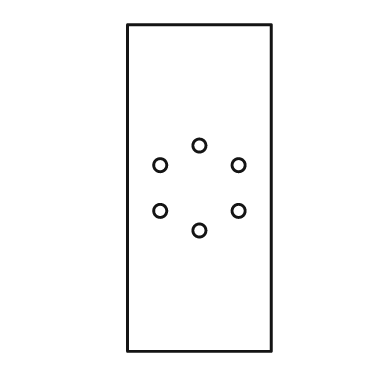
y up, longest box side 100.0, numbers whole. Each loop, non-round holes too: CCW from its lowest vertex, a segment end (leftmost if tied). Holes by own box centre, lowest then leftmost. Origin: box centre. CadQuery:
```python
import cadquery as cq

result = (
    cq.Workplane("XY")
    .moveTo(-22.0, -50.0)
    .lineTo(22.0, -50.0)
    .lineTo(22.0, 50.0)
    .lineTo(-22.0, 50.0)
    .close()
    .moveTo(0.0, -13.0)
    .circle(2.0)
    .moveTo(-12.0, -7.0)
    .circle(2.0)
    .moveTo(12.0, -7.0)
    .circle(2.0)
    .moveTo(-12.0, 7.0)
    .circle(2.0)
    .moveTo(12.0, 7.0)
    .circle(2.0)
    .moveTo(0.0, 13.0)
    .circle(2.0)
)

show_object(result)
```